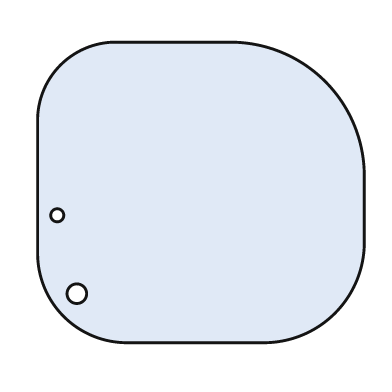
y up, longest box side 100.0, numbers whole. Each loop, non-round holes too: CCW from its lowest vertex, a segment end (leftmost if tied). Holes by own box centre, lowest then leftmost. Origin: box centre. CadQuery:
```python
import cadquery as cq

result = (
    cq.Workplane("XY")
    .moveTo(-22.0, -46.0)
    .lineTo(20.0, -46.0)
    .threePointArc((41.0, -37.0), (50.0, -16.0))
    .lineTo(50.0, 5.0)
    .threePointArc((38.0, 34.0), (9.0, 46.0))
    .lineTo(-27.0, 46.0)
    .threePointArc((-43.0, 39.0), (-50.0, 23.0))
    .lineTo(-50.0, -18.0)
    .threePointArc((-42.0, -38.0), (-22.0, -46.0))
    .close()
    .moveTo(-38.0, -31.0)
    .circle(3.0)
    .moveTo(-44.0, -7.0)
    .circle(2.0)
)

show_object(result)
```